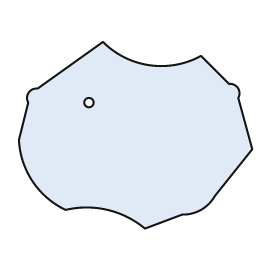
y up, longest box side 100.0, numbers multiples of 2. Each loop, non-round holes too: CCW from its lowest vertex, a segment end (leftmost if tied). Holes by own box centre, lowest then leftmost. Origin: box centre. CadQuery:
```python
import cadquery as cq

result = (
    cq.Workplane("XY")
    .moveTo(4.0, -40.0)
    .lineTo(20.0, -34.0)
    .threePointArc((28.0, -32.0), (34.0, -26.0))
    .lineTo(50.0, -6.0)
    .lineTo(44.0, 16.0)
    .threePointArc((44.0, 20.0), (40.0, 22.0))
    .lineTo(28.0, 34.0)
    .threePointArc((6.0, 30.0), (-14.0, 40.0))
    .lineTo(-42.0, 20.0)
    .threePointArc((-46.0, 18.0), (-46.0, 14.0))
    .lineTo(-50.0, -2.0)
    .threePointArc((-44.0, -20.0), (-30.0, -32.0))
    .threePointArc((-12.0, -32.0), (4.0, -40.0))
    .close()
    .moveTo(-20.0, 14.0)
    .circle(2.0)
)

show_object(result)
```